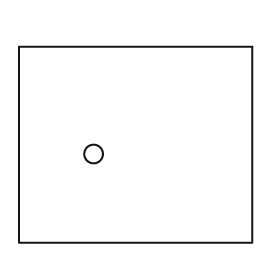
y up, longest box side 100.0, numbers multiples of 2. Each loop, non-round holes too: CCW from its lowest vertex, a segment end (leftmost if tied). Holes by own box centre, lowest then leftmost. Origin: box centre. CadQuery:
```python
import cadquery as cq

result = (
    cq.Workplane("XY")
    .moveTo(-50.0, -42.0)
    .lineTo(50.0, -42.0)
    .lineTo(50.0, 42.0)
    .lineTo(-50.0, 42.0)
    .close()
    .moveTo(-18.0, -4.0)
    .circle(4.0)
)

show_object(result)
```